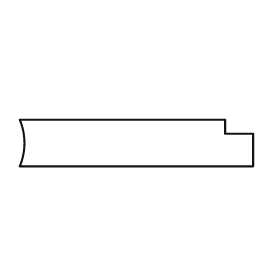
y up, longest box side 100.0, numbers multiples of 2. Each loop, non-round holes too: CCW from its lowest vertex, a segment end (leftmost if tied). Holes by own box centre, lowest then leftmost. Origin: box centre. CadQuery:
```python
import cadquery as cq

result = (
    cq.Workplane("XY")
    .moveTo(-50.0, -10.0)
    .lineTo(50.0, -10.0)
    .lineTo(50.0, 4.0)
    .lineTo(38.0, 4.0)
    .lineTo(38.0, 10.0)
    .lineTo(-50.0, 10.0)
    .threePointArc((-48.0, 0.0), (-50.0, -10.0))
    .close()
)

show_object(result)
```